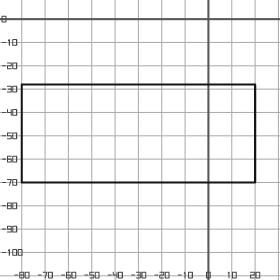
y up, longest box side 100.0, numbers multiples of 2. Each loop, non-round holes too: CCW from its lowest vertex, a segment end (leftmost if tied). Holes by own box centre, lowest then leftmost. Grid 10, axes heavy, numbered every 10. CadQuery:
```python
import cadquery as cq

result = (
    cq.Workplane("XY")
    .moveTo(-80.0, -70.0)
    .lineTo(20.0, -70.0)
    .lineTo(20.0, -28.0)
    .lineTo(-80.0, -28.0)
    .close()
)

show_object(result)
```